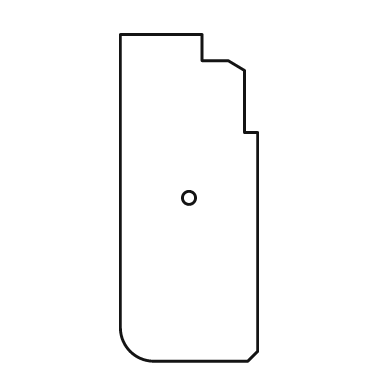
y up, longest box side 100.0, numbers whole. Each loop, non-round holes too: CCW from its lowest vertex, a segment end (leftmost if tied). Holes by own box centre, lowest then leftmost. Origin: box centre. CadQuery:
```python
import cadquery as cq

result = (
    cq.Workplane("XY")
    .moveTo(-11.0, -50.0)
    .lineTo(18.0, -50.0)
    .lineTo(21.0, -47.0)
    .lineTo(21.0, 20.0)
    .lineTo(17.0, 20.0)
    .lineTo(17.0, 39.0)
    .lineTo(12.0, 42.0)
    .lineTo(4.0, 42.0)
    .lineTo(4.0, 50.0)
    .lineTo(-21.0, 50.0)
    .lineTo(-21.0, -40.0)
    .threePointArc((-18.0, -47.0), (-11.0, -50.0))
    .close()
    .moveTo(0.0, 0.0)
    .circle(2.0)
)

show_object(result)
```